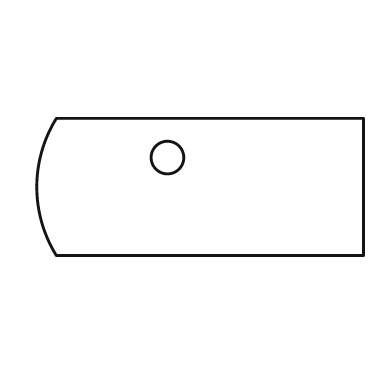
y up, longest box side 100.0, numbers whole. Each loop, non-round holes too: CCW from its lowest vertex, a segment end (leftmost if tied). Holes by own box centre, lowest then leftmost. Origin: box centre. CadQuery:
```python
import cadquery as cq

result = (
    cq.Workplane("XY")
    .moveTo(-44.0, -21.0)
    .lineTo(50.0, -21.0)
    .lineTo(50.0, 21.0)
    .lineTo(-44.0, 21.0)
    .threePointArc((-50.0, 0.0), (-44.0, -21.0))
    .close()
    .moveTo(-10.0, 9.0)
    .circle(5.0)
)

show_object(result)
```